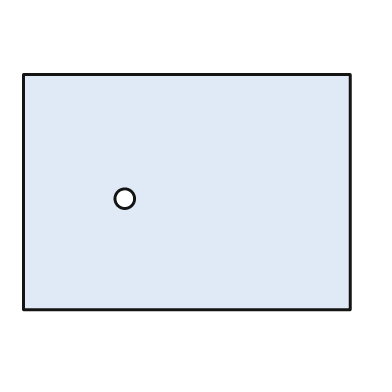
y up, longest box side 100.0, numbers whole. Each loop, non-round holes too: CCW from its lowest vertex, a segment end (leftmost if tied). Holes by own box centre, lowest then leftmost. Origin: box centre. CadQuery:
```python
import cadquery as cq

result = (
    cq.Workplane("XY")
    .moveTo(-50.0, -36.0)
    .lineTo(50.0, -36.0)
    .lineTo(50.0, 36.0)
    .lineTo(-50.0, 36.0)
    .close()
    .moveTo(-19.0, -2.0)
    .circle(3.0)
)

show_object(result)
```